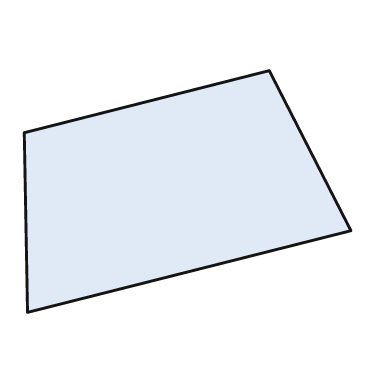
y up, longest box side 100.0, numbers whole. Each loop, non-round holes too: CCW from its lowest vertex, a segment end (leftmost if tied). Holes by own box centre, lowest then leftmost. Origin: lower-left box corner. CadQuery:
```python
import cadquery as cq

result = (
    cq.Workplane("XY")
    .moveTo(1.0, 0.0)
    .lineTo(100.0, 25.0)
    .lineTo(75.0, 74.0)
    .lineTo(0.0, 55.0)
    .close()
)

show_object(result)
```